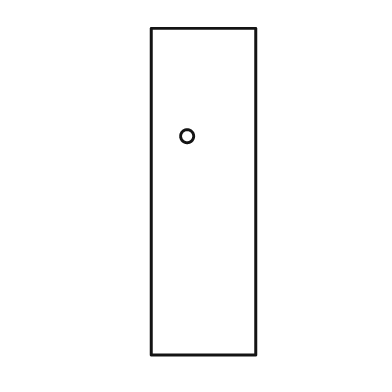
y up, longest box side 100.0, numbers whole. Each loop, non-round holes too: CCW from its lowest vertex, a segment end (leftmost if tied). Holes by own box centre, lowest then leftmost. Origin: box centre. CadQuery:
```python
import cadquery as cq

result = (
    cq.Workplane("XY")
    .moveTo(-16.0, -50.0)
    .lineTo(16.0, -50.0)
    .lineTo(16.0, 50.0)
    .lineTo(-16.0, 50.0)
    .close()
    .moveTo(-5.0, 17.0)
    .circle(2.0)
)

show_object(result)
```